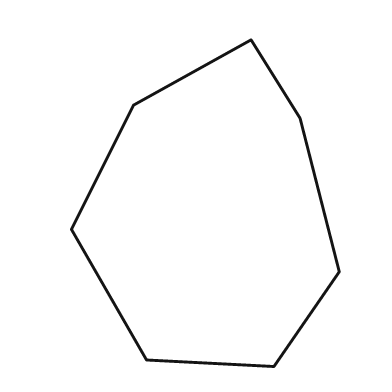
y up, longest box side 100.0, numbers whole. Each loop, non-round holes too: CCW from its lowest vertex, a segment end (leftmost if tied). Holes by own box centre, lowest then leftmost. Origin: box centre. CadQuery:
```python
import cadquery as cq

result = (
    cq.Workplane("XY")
    .moveTo(21.0, -50.0)
    .lineTo(41.0, -21.0)
    .lineTo(29.0, 26.0)
    .lineTo(14.0, 50.0)
    .lineTo(-22.0, 30.0)
    .lineTo(-41.0, -8.0)
    .lineTo(-18.0, -48.0)
    .close()
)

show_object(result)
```